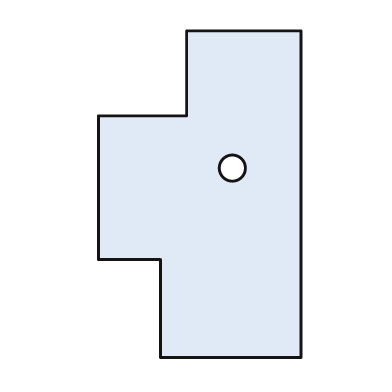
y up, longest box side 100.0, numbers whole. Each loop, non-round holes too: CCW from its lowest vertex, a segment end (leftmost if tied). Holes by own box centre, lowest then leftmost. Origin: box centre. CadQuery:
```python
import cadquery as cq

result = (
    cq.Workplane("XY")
    .moveTo(-12.0, -50.0)
    .lineTo(31.0, -50.0)
    .lineTo(31.0, 50.0)
    .lineTo(-4.0, 50.0)
    .lineTo(-4.0, 24.0)
    .lineTo(-31.0, 24.0)
    .lineTo(-31.0, -20.0)
    .lineTo(-12.0, -20.0)
    .close()
    .moveTo(10.0, 8.0)
    .circle(4.0)
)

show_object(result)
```